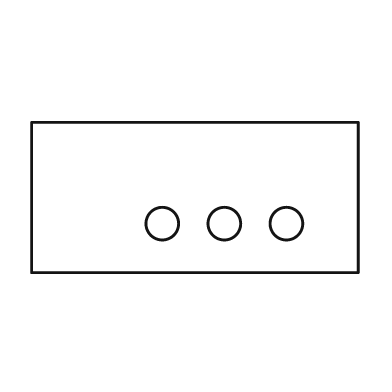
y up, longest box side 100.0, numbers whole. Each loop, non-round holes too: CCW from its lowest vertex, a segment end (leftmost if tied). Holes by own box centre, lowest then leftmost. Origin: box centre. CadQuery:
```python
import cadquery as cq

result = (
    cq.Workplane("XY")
    .moveTo(-50.0, -23.0)
    .lineTo(50.0, -23.0)
    .lineTo(50.0, 23.0)
    .lineTo(-50.0, 23.0)
    .close()
    .moveTo(-10.0, -8.0)
    .circle(5.0)
    .moveTo(9.0, -8.0)
    .circle(5.0)
    .moveTo(28.0, -8.0)
    .circle(5.0)
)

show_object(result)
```